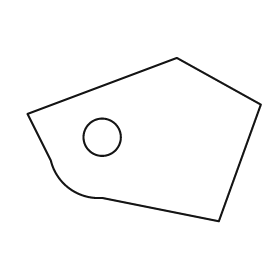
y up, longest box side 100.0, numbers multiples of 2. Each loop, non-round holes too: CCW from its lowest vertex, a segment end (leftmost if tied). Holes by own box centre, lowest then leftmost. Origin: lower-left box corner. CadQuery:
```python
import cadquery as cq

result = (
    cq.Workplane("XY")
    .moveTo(82.0, 0.0)
    .lineTo(100.0, 50.0)
    .lineTo(64.0, 70.0)
    .lineTo(0.0, 46.0)
    .lineTo(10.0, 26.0)
    .threePointArc((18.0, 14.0), (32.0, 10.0))
    .close()
    .moveTo(32.0, 36.0)
    .circle(8.0)
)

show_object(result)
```